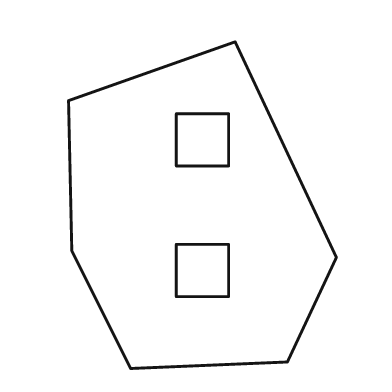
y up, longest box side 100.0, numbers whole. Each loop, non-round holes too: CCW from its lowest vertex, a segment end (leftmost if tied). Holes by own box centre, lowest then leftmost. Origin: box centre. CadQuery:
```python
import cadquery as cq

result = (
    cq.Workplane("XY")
    .moveTo(-22.0, -50.0)
    .lineTo(26.0, -48.0)
    .lineTo(41.0, -16.0)
    .lineTo(10.0, 50.0)
    .lineTo(-41.0, 32.0)
    .lineTo(-40.0, -14.0)
    .close()
    .moveTo(-8.0, -28.0)
    .lineTo(8.0, -28.0)
    .lineTo(8.0, -12.0)
    .lineTo(-8.0, -12.0)
    .close()
    .moveTo(-8.0, 12.0)
    .lineTo(8.0, 12.0)
    .lineTo(8.0, 28.0)
    .lineTo(-8.0, 28.0)
    .close()
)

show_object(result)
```